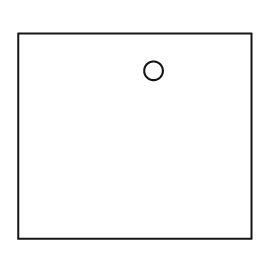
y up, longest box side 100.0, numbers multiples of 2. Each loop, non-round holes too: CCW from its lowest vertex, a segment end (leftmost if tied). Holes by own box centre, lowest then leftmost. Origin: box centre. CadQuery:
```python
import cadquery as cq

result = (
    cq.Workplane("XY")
    .moveTo(-50.0, -44.0)
    .lineTo(50.0, -44.0)
    .lineTo(50.0, 44.0)
    .lineTo(-50.0, 44.0)
    .close()
    .moveTo(8.0, 28.0)
    .circle(4.0)
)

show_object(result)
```